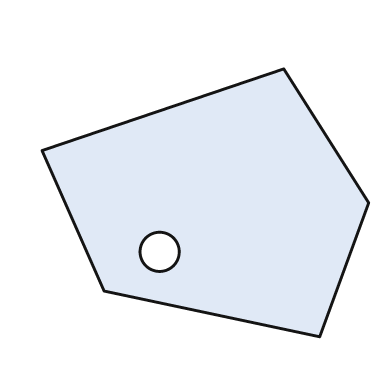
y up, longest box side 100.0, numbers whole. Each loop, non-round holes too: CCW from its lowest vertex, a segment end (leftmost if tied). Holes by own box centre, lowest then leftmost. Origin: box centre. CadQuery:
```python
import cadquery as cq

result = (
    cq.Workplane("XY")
    .moveTo(35.0, -41.0)
    .lineTo(50.0, 0.0)
    .lineTo(24.0, 41.0)
    .lineTo(-50.0, 16.0)
    .lineTo(-31.0, -27.0)
    .close()
    .moveTo(-14.0, -15.0)
    .circle(6.0)
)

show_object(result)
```